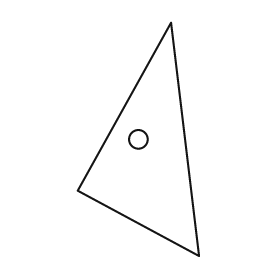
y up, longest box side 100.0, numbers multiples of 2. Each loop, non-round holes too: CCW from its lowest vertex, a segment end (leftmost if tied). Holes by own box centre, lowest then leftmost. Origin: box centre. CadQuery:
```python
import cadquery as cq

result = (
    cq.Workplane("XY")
    .moveTo(26.0, -50.0)
    .lineTo(14.0, 50.0)
    .lineTo(-26.0, -22.0)
    .close()
    .moveTo(0.0, 0.0)
    .circle(4.0)
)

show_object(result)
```